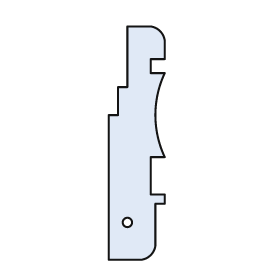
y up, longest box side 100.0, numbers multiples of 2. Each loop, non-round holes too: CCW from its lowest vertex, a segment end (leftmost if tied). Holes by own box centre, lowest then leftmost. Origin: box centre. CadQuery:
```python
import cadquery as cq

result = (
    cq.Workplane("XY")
    .moveTo(-12.0, -50.0)
    .lineTo(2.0, -50.0)
    .threePointArc((6.0, -48.0), (8.0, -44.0))
    .lineTo(8.0, -26.0)
    .lineTo(12.0, -26.0)
    .lineTo(12.0, -22.0)
    .lineTo(6.0, -22.0)
    .lineTo(6.0, -6.0)
    .lineTo(12.0, -6.0)
    .threePointArc((8.0, 12.0), (12.0, 30.0))
    .lineTo(6.0, 30.0)
    .lineTo(6.0, 36.0)
    .lineTo(12.0, 36.0)
    .lineTo(12.0, 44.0)
    .threePointArc((10.0, 48.0), (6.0, 50.0))
    .lineTo(-4.0, 50.0)
    .lineTo(-4.0, 24.0)
    .lineTo(-8.0, 24.0)
    .lineTo(-8.0, 12.0)
    .lineTo(-12.0, 12.0)
    .close()
    .moveTo(-4.0, -34.0)
    .circle(2.0)
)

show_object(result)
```